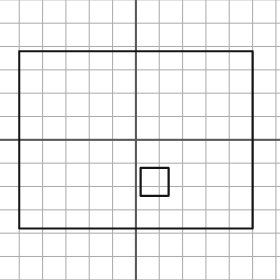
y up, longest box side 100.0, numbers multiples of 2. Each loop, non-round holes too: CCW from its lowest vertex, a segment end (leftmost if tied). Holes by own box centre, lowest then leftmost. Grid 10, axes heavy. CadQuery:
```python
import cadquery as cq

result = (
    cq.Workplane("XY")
    .moveTo(-50.0, -38.0)
    .lineTo(50.0, -38.0)
    .lineTo(50.0, 38.0)
    .lineTo(-50.0, 38.0)
    .close()
    .moveTo(2.0, -24.0)
    .lineTo(14.0, -24.0)
    .lineTo(14.0, -12.0)
    .lineTo(2.0, -12.0)
    .close()
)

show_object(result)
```